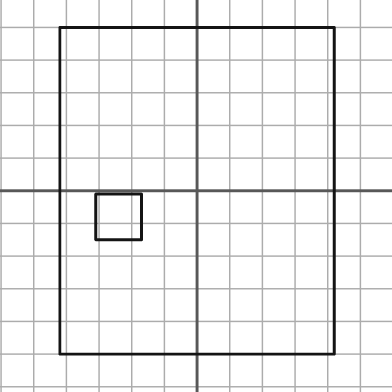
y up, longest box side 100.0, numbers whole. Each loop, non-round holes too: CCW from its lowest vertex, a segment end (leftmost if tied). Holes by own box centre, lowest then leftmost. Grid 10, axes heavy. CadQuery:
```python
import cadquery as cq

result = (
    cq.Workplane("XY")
    .moveTo(-42.0, -50.0)
    .lineTo(42.0, -50.0)
    .lineTo(42.0, 50.0)
    .lineTo(-42.0, 50.0)
    .close()
    .moveTo(-31.0, -15.0)
    .lineTo(-17.0, -15.0)
    .lineTo(-17.0, -1.0)
    .lineTo(-31.0, -1.0)
    .close()
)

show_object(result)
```